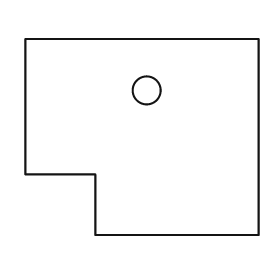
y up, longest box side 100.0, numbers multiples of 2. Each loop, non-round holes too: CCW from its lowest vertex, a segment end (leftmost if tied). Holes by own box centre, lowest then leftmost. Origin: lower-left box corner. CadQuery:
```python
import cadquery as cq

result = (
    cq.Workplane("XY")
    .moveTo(30.0, 0.0)
    .lineTo(100.0, 0.0)
    .lineTo(100.0, 84.0)
    .lineTo(0.0, 84.0)
    .lineTo(0.0, 26.0)
    .lineTo(30.0, 26.0)
    .close()
    .moveTo(52.0, 62.0)
    .circle(6.0)
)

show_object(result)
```